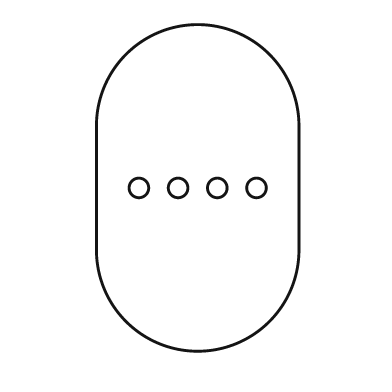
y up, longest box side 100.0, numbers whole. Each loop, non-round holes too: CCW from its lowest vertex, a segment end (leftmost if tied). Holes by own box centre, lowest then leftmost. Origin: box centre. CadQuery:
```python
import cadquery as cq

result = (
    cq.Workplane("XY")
    .moveTo(-31.0, -19.0)
    .threePointArc((0.0, -50.0), (31.0, -19.0))
    .lineTo(31.0, 19.0)
    .threePointArc((0.0, 50.0), (-31.0, 19.0))
    .close()
    .moveTo(-18.0, 0.0)
    .circle(3.0)
    .moveTo(-6.0, 0.0)
    .circle(3.0)
    .moveTo(6.0, 0.0)
    .circle(3.0)
    .moveTo(18.0, 0.0)
    .circle(3.0)
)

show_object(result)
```